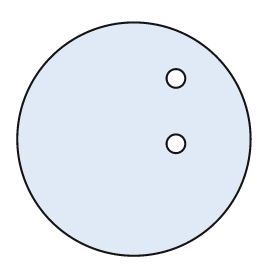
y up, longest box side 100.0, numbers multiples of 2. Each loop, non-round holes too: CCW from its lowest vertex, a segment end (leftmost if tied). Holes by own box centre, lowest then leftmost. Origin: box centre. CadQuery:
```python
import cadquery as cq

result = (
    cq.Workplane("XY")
    .moveTo(0.0, 0.0)
    .circle(50.0)
    .moveTo(18.0, -2.0)
    .circle(4.0)
    .moveTo(18.0, 26.0)
    .circle(4.0)
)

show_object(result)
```